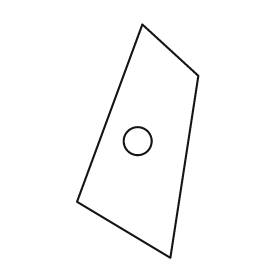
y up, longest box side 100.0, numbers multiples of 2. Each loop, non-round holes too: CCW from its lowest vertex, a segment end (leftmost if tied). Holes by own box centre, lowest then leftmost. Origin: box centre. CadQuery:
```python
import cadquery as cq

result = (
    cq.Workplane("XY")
    .moveTo(14.0, -50.0)
    .lineTo(26.0, 28.0)
    .lineTo(2.0, 50.0)
    .lineTo(-26.0, -26.0)
    .close()
    .moveTo(0.0, 0.0)
    .circle(6.0)
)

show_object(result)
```